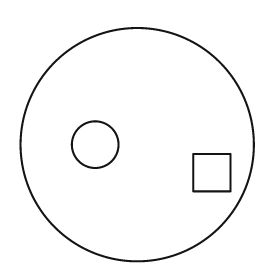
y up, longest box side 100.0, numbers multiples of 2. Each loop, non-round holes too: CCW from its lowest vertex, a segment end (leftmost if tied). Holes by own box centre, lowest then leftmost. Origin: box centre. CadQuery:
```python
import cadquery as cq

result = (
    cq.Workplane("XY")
    .moveTo(0.0, 0.0)
    .circle(50.0)
    .moveTo(24.0, -20.0)
    .lineTo(40.0, -20.0)
    .lineTo(40.0, -4.0)
    .lineTo(24.0, -4.0)
    .close()
    .moveTo(-18.0, 0.0)
    .circle(10.0)
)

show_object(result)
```